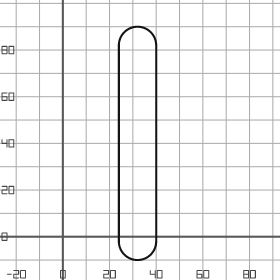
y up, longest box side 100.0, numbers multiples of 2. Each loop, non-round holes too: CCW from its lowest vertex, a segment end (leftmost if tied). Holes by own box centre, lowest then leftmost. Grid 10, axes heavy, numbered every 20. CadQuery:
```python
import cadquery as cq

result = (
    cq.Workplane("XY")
    .moveTo(24.0, -2.0)
    .threePointArc((32.0, -10.0), (40.0, -2.0))
    .lineTo(40.0, 82.0)
    .threePointArc((32.0, 90.0), (24.0, 82.0))
    .close()
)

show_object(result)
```